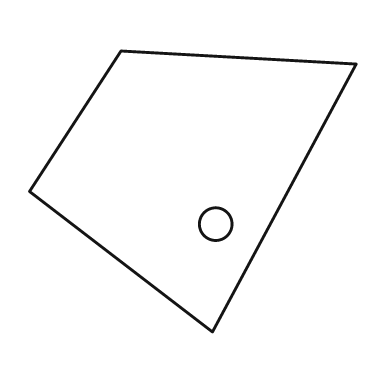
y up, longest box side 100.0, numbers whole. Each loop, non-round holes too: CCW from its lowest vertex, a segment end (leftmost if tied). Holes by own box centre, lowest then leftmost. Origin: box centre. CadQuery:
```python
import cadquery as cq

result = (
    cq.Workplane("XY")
    .moveTo(6.0, -43.0)
    .lineTo(50.0, 39.0)
    .lineTo(-22.0, 43.0)
    .lineTo(-50.0, 0.0)
    .close()
    .moveTo(7.0, -10.0)
    .circle(5.0)
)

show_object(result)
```